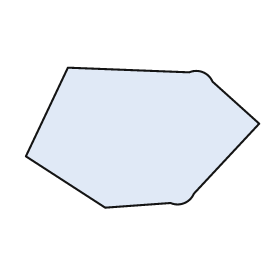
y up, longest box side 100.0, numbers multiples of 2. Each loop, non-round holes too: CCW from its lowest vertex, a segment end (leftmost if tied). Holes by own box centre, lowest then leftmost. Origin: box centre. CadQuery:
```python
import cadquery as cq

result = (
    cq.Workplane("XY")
    .moveTo(-16.0, -30.0)
    .lineTo(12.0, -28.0)
    .threePointArc((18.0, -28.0), (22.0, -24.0))
    .lineTo(50.0, 6.0)
    .lineTo(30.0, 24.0)
    .threePointArc((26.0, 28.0), (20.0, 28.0))
    .lineTo(-32.0, 30.0)
    .lineTo(-50.0, -8.0)
    .close()
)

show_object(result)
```